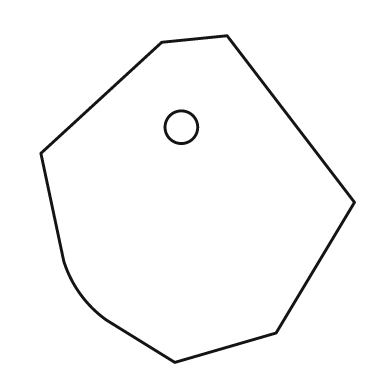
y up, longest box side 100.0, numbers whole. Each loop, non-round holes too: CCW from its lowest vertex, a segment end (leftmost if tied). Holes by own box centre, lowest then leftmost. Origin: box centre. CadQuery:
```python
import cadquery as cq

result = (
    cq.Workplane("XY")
    .moveTo(-7.0, -50.0)
    .lineTo(24.0, -41.0)
    .lineTo(48.0, -1.0)
    .lineTo(9.0, 50.0)
    .lineTo(-11.0, 48.0)
    .lineTo(-48.0, 14.0)
    .lineTo(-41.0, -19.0)
    .threePointArc((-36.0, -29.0), (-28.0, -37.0))
    .close()
    .moveTo(-5.0, 22.0)
    .circle(5.0)
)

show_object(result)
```